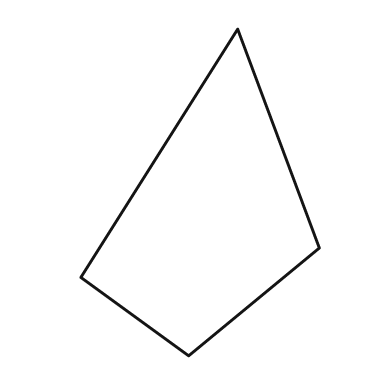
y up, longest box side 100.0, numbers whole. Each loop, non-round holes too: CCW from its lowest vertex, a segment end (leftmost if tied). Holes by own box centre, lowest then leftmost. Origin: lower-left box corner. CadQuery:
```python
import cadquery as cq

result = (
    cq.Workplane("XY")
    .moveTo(33.0, 0.0)
    .lineTo(73.0, 33.0)
    .lineTo(48.0, 100.0)
    .lineTo(0.0, 24.0)
    .close()
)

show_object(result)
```